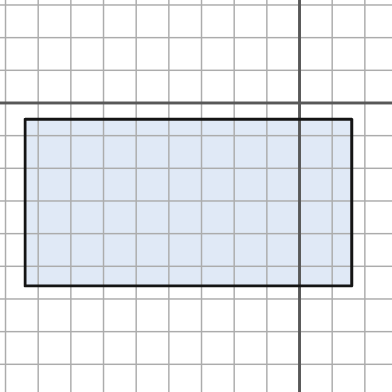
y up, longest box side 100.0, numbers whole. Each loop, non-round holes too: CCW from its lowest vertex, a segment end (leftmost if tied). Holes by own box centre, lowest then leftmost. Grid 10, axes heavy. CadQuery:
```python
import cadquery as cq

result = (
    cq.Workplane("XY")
    .moveTo(-84.0, -56.0)
    .lineTo(16.0, -56.0)
    .lineTo(16.0, -5.0)
    .lineTo(-84.0, -5.0)
    .close()
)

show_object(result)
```